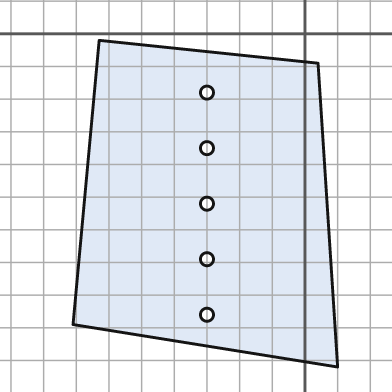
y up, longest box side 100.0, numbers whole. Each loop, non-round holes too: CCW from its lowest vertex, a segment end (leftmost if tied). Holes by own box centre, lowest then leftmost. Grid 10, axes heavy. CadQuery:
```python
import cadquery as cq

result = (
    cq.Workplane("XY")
    .moveTo(10.0, -102.0)
    .lineTo(4.0, -9.0)
    .lineTo(-63.0, -2.0)
    .lineTo(-71.0, -89.0)
    .close()
    .moveTo(-30.0, -86.0)
    .circle(2.0)
    .moveTo(-30.0, -69.0)
    .circle(2.0)
    .moveTo(-30.0, -52.0)
    .circle(2.0)
    .moveTo(-30.0, -35.0)
    .circle(2.0)
    .moveTo(-30.0, -18.0)
    .circle(2.0)
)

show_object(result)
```